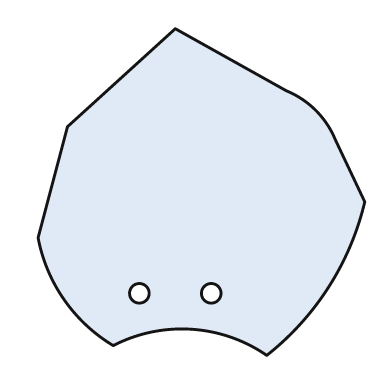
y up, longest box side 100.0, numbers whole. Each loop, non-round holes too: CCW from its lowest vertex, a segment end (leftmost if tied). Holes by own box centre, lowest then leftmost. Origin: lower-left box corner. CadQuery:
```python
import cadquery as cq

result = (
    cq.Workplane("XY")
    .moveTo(70.0, 0.0)
    .threePointArc((89.0, 21.0), (100.0, 47.0))
    .lineTo(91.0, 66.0)
    .threePointArc((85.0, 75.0), (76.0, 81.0))
    .lineTo(42.0, 100.0)
    .lineTo(9.0, 70.0)
    .lineTo(0.0, 36.0)
    .threePointArc((8.0, 17.0), (23.0, 3.0))
    .threePointArc((47.0, 8.0), (70.0, 0.0))
    .close()
    .moveTo(31.0, 19.0)
    .circle(3.0)
    .moveTo(53.0, 19.0)
    .circle(3.0)
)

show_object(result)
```